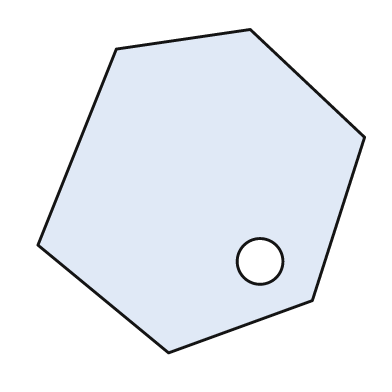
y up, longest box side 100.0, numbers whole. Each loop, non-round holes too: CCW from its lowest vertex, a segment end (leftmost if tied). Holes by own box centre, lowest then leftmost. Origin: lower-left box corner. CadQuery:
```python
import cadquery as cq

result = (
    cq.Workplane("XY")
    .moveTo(40.0, 0.0)
    .lineTo(84.0, 16.0)
    .lineTo(100.0, 66.0)
    .lineTo(65.0, 99.0)
    .lineTo(24.0, 93.0)
    .lineTo(0.0, 33.0)
    .close()
    .moveTo(68.0, 28.0)
    .circle(7.0)
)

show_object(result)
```